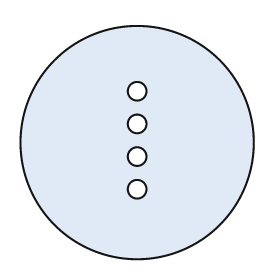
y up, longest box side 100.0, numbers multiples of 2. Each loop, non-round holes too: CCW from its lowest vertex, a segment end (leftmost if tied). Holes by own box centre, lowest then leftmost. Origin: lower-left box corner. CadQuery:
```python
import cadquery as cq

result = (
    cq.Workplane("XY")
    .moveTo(50.0, 50.0)
    .circle(50.0)
    .moveTo(50.0, 30.0)
    .circle(4.0)
    .moveTo(50.0, 44.0)
    .circle(4.0)
    .moveTo(50.0, 58.0)
    .circle(4.0)
    .moveTo(50.0, 72.0)
    .circle(4.0)
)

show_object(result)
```